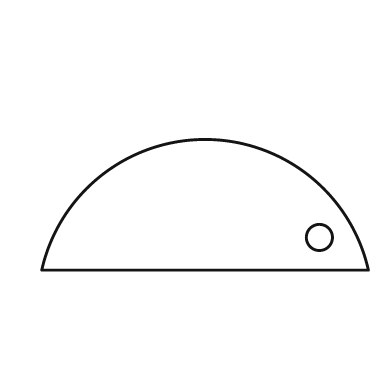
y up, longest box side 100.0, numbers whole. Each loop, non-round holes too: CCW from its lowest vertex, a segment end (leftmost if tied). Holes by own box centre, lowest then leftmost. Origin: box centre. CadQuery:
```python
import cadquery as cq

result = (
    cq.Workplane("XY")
    .moveTo(-50.0, -20.0)
    .lineTo(50.0, -20.0)
    .threePointArc((0.0, 20.0), (-50.0, -20.0))
    .close()
    .moveTo(35.0, -10.0)
    .circle(4.0)
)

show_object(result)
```